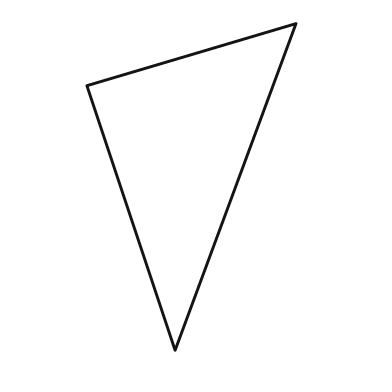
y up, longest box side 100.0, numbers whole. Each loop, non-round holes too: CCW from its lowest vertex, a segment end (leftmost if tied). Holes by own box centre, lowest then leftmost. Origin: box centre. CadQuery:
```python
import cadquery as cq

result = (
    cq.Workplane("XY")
    .moveTo(-5.0, -50.0)
    .lineTo(32.0, 50.0)
    .lineTo(-32.0, 31.0)
    .close()
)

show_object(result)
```